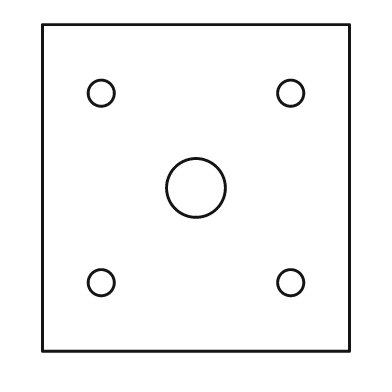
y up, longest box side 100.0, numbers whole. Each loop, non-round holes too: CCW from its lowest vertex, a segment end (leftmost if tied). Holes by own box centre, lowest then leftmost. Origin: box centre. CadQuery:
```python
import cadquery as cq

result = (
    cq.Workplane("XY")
    .moveTo(-47.0, -50.0)
    .lineTo(47.0, -50.0)
    .lineTo(47.0, 50.0)
    .lineTo(-47.0, 50.0)
    .close()
    .moveTo(-29.0, -29.0)
    .circle(4.0)
    .moveTo(29.0, -29.0)
    .circle(4.0)
    .moveTo(0.0, 0.0)
    .circle(9.0)
    .moveTo(-29.0, 29.0)
    .circle(4.0)
    .moveTo(29.0, 29.0)
    .circle(4.0)
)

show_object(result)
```